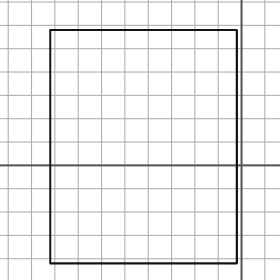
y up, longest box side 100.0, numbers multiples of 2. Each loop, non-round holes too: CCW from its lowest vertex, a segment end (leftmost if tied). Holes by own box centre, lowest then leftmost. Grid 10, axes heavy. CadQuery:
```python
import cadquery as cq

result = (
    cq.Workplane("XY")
    .moveTo(-82.0, -42.0)
    .lineTo(-2.0, -42.0)
    .lineTo(-2.0, 58.0)
    .lineTo(-82.0, 58.0)
    .close()
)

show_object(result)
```